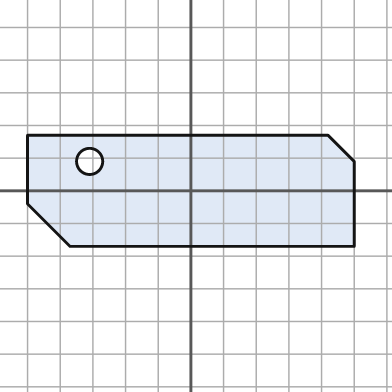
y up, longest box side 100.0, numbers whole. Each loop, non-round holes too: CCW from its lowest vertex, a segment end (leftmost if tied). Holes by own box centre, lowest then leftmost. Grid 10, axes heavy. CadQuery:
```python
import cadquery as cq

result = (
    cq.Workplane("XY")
    .moveTo(-37.0, -17.0)
    .lineTo(50.0, -17.0)
    .lineTo(50.0, 9.0)
    .lineTo(42.0, 17.0)
    .lineTo(-50.0, 17.0)
    .lineTo(-50.0, -4.0)
    .close()
    .moveTo(-31.0, 9.0)
    .circle(4.0)
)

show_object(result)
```